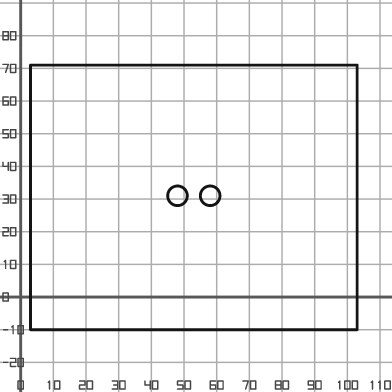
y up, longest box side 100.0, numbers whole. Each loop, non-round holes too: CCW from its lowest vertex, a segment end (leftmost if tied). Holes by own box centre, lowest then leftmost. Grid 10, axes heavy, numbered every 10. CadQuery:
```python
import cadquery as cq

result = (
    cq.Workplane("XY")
    .moveTo(3.0, -10.0)
    .lineTo(103.0, -10.0)
    .lineTo(103.0, 71.0)
    .lineTo(3.0, 71.0)
    .close()
    .moveTo(48.0, 31.0)
    .circle(3.0)
    .moveTo(58.0, 31.0)
    .circle(3.0)
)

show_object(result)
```